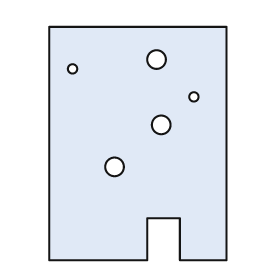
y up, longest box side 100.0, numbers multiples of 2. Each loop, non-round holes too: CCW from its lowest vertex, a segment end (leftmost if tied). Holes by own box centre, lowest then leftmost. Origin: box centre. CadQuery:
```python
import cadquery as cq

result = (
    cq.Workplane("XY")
    .moveTo(-38.0, -50.0)
    .lineTo(4.0, -50.0)
    .lineTo(4.0, -32.0)
    .lineTo(18.0, -32.0)
    .lineTo(18.0, -50.0)
    .lineTo(38.0, -50.0)
    .lineTo(38.0, 50.0)
    .lineTo(-38.0, 50.0)
    .close()
    .moveTo(-10.0, -10.0)
    .circle(4.0)
    .moveTo(10.0, 8.0)
    .circle(4.0)
    .moveTo(24.0, 20.0)
    .circle(2.0)
    .moveTo(-28.0, 32.0)
    .circle(2.0)
    .moveTo(8.0, 36.0)
    .circle(4.0)
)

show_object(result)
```